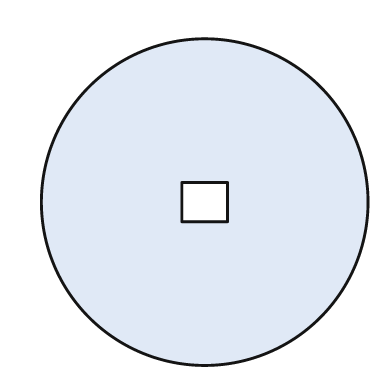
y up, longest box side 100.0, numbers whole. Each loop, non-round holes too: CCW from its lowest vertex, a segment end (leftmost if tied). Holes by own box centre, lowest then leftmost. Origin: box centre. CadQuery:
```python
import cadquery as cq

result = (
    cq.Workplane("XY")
    .moveTo(0.0, 0.0)
    .circle(50.0)
    .moveTo(-7.0, -6.0)
    .lineTo(7.0, -6.0)
    .lineTo(7.0, 6.0)
    .lineTo(-7.0, 6.0)
    .close()
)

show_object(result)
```